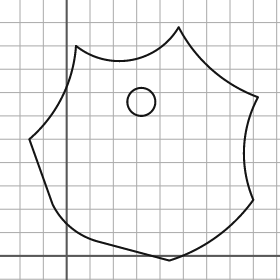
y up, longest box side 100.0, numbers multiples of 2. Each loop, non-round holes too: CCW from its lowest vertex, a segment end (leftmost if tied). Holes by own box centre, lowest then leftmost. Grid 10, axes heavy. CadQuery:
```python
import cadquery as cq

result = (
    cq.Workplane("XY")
    .moveTo(44.0, -2.0)
    .threePointArc((64.0, 8.0), (80.0, 24.0))
    .threePointArc((76.0, 46.0), (82.0, 68.0))
    .threePointArc((62.0, 80.0), (48.0, 98.0))
    .threePointArc((28.0, 84.0), (4.0, 90.0))
    .threePointArc((-2.0, 68.0), (-16.0, 50.0))
    .lineTo(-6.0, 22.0)
    .threePointArc((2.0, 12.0), (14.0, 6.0))
    .close()
    .moveTo(32.0, 66.0)
    .circle(6.0)
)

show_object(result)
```